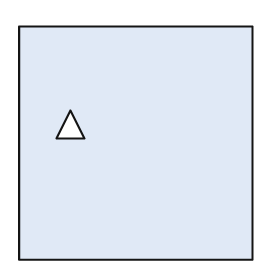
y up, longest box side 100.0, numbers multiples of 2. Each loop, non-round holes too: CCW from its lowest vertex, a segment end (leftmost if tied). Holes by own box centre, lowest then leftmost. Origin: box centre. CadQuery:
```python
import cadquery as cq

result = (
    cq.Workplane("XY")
    .moveTo(-50.0, -50.0)
    .lineTo(50.0, -50.0)
    .lineTo(50.0, 50.0)
    .lineTo(-50.0, 50.0)
    .close()
    .moveTo(-34.0, 2.0)
    .lineTo(-22.0, 2.0)
    .lineTo(-28.0, 14.0)
    .close()
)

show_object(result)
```